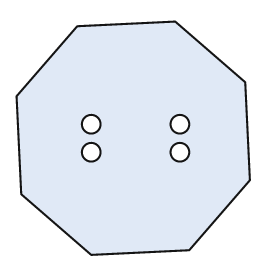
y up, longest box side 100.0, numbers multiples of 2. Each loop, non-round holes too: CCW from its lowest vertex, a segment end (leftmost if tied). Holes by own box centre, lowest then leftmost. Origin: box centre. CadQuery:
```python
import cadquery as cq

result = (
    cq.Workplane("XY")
    .moveTo(-18.0, -50.0)
    .lineTo(24.0, -48.0)
    .lineTo(50.0, -18.0)
    .lineTo(48.0, 24.0)
    .lineTo(18.0, 50.0)
    .lineTo(-24.0, 48.0)
    .lineTo(-50.0, 18.0)
    .lineTo(-48.0, -24.0)
    .close()
    .moveTo(-18.0, -6.0)
    .circle(4.0)
    .moveTo(20.0, -6.0)
    .circle(4.0)
    .moveTo(-18.0, 6.0)
    .circle(4.0)
    .moveTo(20.0, 6.0)
    .circle(4.0)
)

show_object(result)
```